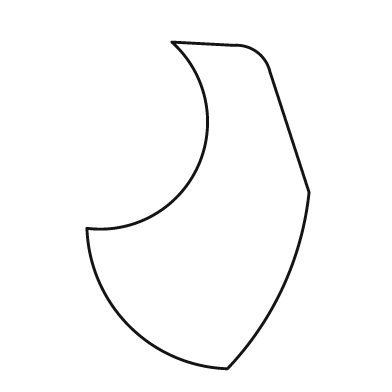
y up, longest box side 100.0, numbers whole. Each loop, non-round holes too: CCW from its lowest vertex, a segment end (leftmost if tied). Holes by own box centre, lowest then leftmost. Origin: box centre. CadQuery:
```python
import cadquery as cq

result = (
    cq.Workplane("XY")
    .moveTo(9.0, -50.0)
    .threePointArc((26.0, -25.0), (34.0, 4.0))
    .lineTo(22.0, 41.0)
    .threePointArc((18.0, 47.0), (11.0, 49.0))
    .lineTo(-8.0, 50.0)
    .threePointArc((0.0, 12.0), (-34.0, -7.0))
    .threePointArc((-21.0, -37.0), (9.0, -50.0))
    .close()
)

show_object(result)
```